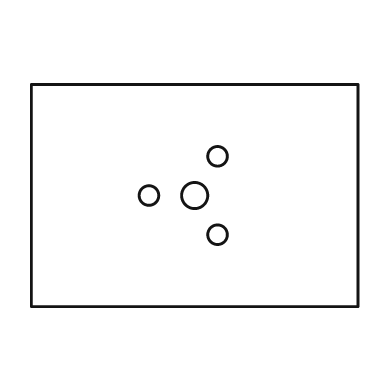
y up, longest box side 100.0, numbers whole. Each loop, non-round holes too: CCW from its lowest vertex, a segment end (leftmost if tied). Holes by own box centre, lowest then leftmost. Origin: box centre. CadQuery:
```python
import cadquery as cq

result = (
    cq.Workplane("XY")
    .moveTo(-50.0, -34.0)
    .lineTo(50.0, -34.0)
    .lineTo(50.0, 34.0)
    .lineTo(-50.0, 34.0)
    .close()
    .moveTo(7.0, -12.0)
    .circle(3.0)
    .moveTo(-14.0, 0.0)
    .circle(3.0)
    .moveTo(0.0, 0.0)
    .circle(4.0)
    .moveTo(7.0, 12.0)
    .circle(3.0)
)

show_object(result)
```